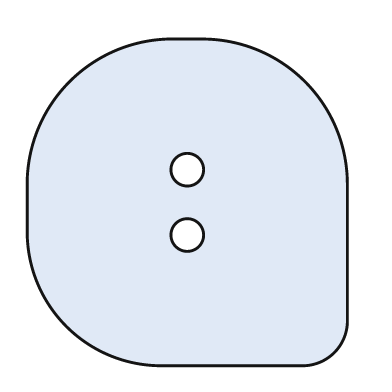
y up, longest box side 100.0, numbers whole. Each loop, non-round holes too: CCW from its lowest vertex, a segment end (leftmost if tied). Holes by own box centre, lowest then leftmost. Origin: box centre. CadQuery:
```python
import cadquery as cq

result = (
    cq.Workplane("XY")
    .moveTo(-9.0, -50.0)
    .lineTo(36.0, -50.0)
    .threePointArc((45.0, -46.0), (49.0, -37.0))
    .lineTo(49.0, 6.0)
    .threePointArc((36.0, 37.0), (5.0, 50.0))
    .lineTo(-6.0, 50.0)
    .threePointArc((-36.0, 37.0), (-49.0, 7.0))
    .lineTo(-49.0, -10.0)
    .threePointArc((-37.0, -38.0), (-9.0, -50.0))
    .close()
    .moveTo(0.0, -10.0)
    .circle(5.0)
    .moveTo(0.0, 10.0)
    .circle(5.0)
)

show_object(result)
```